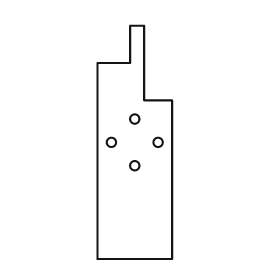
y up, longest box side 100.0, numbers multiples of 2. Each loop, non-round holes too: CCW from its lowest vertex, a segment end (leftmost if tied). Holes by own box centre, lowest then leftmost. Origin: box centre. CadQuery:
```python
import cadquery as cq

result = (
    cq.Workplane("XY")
    .moveTo(-16.0, -50.0)
    .lineTo(16.0, -50.0)
    .lineTo(16.0, 18.0)
    .lineTo(4.0, 18.0)
    .lineTo(4.0, 50.0)
    .lineTo(-2.0, 50.0)
    .lineTo(-2.0, 34.0)
    .lineTo(-16.0, 34.0)
    .close()
    .moveTo(0.0, -10.0)
    .circle(2.0)
    .moveTo(-10.0, 0.0)
    .circle(2.0)
    .moveTo(10.0, 0.0)
    .circle(2.0)
    .moveTo(0.0, 10.0)
    .circle(2.0)
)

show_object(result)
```